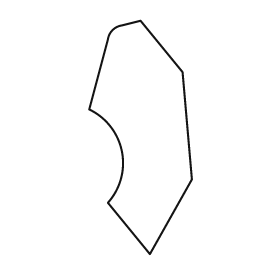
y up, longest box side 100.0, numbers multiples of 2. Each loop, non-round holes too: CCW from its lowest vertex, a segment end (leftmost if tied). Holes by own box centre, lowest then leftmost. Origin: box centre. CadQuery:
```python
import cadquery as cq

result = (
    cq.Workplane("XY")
    .moveTo(4.0, -50.0)
    .lineTo(22.0, -18.0)
    .lineTo(18.0, 28.0)
    .lineTo(0.0, 50.0)
    .lineTo(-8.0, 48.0)
    .threePointArc((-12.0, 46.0), (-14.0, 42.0))
    .lineTo(-22.0, 12.0)
    .threePointArc((-8.0, -6.0), (-14.0, -28.0))
    .close()
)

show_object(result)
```